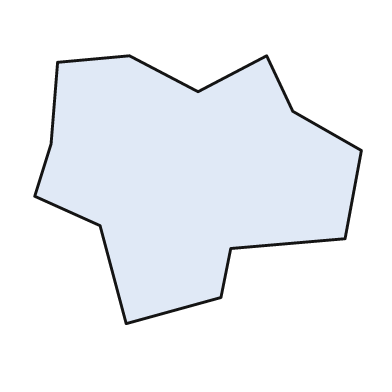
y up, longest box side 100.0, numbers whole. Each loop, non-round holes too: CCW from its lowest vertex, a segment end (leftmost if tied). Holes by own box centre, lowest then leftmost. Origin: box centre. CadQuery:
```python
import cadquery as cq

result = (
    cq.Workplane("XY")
    .moveTo(-22.0, -41.0)
    .lineTo(7.0, -33.0)
    .lineTo(10.0, -18.0)
    .lineTo(45.0, -15.0)
    .lineTo(50.0, 12.0)
    .lineTo(29.0, 24.0)
    .lineTo(21.0, 41.0)
    .lineTo(0.0, 30.0)
    .lineTo(-21.0, 41.0)
    .lineTo(-43.0, 39.0)
    .lineTo(-45.0, 14.0)
    .lineTo(-50.0, -2.0)
    .lineTo(-30.0, -11.0)
    .close()
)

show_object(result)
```